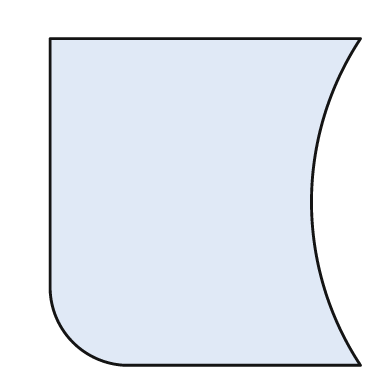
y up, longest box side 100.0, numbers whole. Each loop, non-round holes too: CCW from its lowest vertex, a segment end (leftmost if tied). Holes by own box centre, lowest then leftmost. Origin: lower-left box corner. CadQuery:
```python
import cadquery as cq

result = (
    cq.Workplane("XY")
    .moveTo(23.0, 0.0)
    .lineTo(95.0, 0.0)
    .threePointArc((80.0, 50.0), (95.0, 100.0))
    .lineTo(0.0, 100.0)
    .lineTo(0.0, 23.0)
    .threePointArc((7.0, 7.0), (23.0, 0.0))
    .close()
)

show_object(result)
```